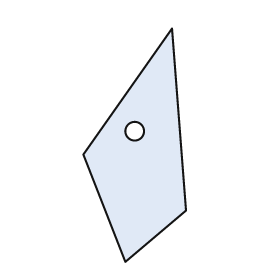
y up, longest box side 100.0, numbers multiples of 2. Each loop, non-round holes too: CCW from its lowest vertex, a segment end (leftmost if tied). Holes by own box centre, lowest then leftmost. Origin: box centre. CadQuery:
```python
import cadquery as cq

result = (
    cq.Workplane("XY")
    .moveTo(-4.0, -50.0)
    .lineTo(22.0, -28.0)
    .lineTo(16.0, 50.0)
    .lineTo(-22.0, -4.0)
    .close()
    .moveTo(0.0, 6.0)
    .circle(4.0)
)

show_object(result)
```